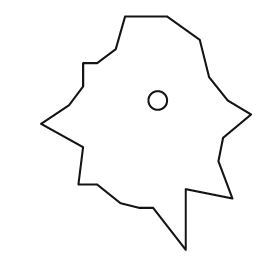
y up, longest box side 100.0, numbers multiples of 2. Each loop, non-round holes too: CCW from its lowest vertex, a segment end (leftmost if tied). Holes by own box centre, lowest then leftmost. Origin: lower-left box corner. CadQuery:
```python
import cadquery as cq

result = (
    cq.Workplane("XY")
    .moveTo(62.0, 0.0)
    .lineTo(62.0, 26.0)
    .lineTo(82.0, 22.0)
    .lineTo(76.0, 38.0)
    .lineTo(78.0, 48.0)
    .lineTo(90.0, 58.0)
    .lineTo(80.0, 64.0)
    .lineTo(72.0, 74.0)
    .lineTo(68.0, 90.0)
    .lineTo(54.0, 100.0)
    .lineTo(36.0, 100.0)
    .lineTo(32.0, 86.0)
    .lineTo(24.0, 80.0)
    .lineTo(18.0, 80.0)
    .lineTo(18.0, 70.0)
    .lineTo(12.0, 62.0)
    .lineTo(0.0, 54.0)
    .lineTo(18.0, 44.0)
    .lineTo(16.0, 28.0)
    .lineTo(24.0, 28.0)
    .lineTo(34.0, 20.0)
    .lineTo(42.0, 18.0)
    .lineTo(48.0, 18.0)
    .close()
    .moveTo(50.0, 64.0)
    .circle(4.0)
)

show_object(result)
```